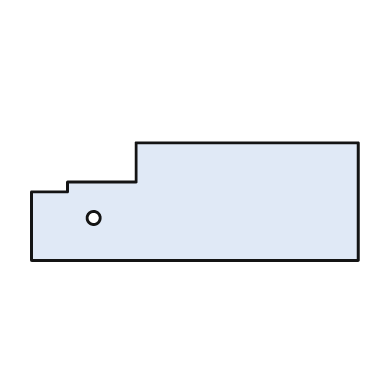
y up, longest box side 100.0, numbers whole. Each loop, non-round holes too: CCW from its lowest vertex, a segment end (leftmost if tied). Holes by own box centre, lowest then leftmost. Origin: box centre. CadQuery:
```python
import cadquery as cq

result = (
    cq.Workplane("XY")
    .moveTo(-50.0, -18.0)
    .lineTo(50.0, -18.0)
    .lineTo(50.0, 18.0)
    .lineTo(-18.0, 18.0)
    .lineTo(-18.0, 6.0)
    .lineTo(-39.0, 6.0)
    .lineTo(-39.0, 3.0)
    .lineTo(-50.0, 3.0)
    .close()
    .moveTo(-31.0, -5.0)
    .circle(2.0)
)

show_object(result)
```